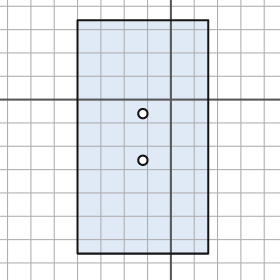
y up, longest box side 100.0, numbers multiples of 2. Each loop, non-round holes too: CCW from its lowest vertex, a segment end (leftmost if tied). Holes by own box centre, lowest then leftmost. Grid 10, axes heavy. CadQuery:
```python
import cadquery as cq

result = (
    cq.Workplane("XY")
    .moveTo(-40.0, -66.0)
    .lineTo(16.0, -66.0)
    .lineTo(16.0, 34.0)
    .lineTo(-40.0, 34.0)
    .close()
    .moveTo(-12.0, -26.0)
    .circle(2.0)
    .moveTo(-12.0, -6.0)
    .circle(2.0)
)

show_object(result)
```